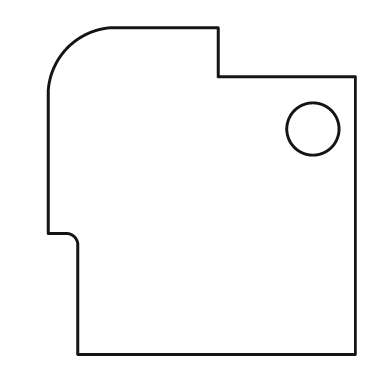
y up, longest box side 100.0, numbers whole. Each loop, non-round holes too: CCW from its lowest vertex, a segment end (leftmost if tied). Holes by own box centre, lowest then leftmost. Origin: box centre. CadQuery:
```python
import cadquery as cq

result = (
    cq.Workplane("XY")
    .moveTo(-38.0, -50.0)
    .lineTo(47.0, -50.0)
    .lineTo(47.0, 35.0)
    .lineTo(5.0, 35.0)
    .lineTo(5.0, 50.0)
    .lineTo(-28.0, 50.0)
    .threePointArc((-41.0, 44.0), (-47.0, 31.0))
    .lineTo(-47.0, -13.0)
    .lineTo(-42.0, -13.0)
    .threePointArc((-39.0, -14.0), (-38.0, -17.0))
    .close()
    .moveTo(34.0, 19.0)
    .circle(8.0)
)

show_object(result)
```